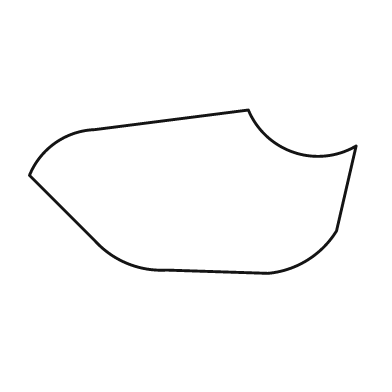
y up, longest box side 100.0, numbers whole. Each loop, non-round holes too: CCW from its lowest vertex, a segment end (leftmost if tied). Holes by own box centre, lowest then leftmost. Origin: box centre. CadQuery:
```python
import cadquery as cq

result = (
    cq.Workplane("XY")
    .moveTo(23.0, -25.0)
    .threePointArc((35.0, -21.0), (44.0, -12.0))
    .lineTo(50.0, 14.0)
    .threePointArc((31.0, 12.0), (17.0, 25.0))
    .lineTo(-30.0, 19.0)
    .threePointArc((-42.0, 15.0), (-50.0, 5.0))
    .lineTo(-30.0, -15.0)
    .threePointArc((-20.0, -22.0), (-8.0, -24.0))
    .close()
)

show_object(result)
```